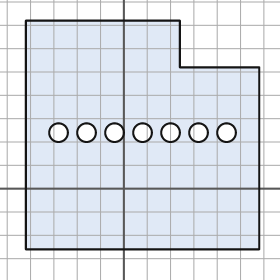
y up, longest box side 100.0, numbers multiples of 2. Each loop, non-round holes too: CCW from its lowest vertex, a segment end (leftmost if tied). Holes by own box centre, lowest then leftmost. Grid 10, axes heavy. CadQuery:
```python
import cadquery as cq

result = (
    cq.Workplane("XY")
    .moveTo(-42.0, -26.0)
    .lineTo(58.0, -26.0)
    .lineTo(58.0, 52.0)
    .lineTo(24.0, 52.0)
    .lineTo(24.0, 72.0)
    .lineTo(-42.0, 72.0)
    .close()
    .moveTo(-28.0, 24.0)
    .circle(4.0)
    .moveTo(-16.0, 24.0)
    .circle(4.0)
    .moveTo(-4.0, 24.0)
    .circle(4.0)
    .moveTo(8.0, 24.0)
    .circle(4.0)
    .moveTo(20.0, 24.0)
    .circle(4.0)
    .moveTo(32.0, 24.0)
    .circle(4.0)
    .moveTo(44.0, 24.0)
    .circle(4.0)
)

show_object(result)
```